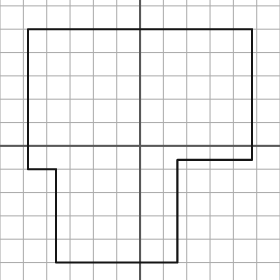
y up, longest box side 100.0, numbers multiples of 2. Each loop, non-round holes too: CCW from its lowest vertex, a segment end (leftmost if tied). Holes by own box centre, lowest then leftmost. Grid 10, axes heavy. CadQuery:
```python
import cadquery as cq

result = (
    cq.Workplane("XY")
    .moveTo(-36.0, -50.0)
    .lineTo(16.0, -50.0)
    .lineTo(16.0, -6.0)
    .lineTo(48.0, -6.0)
    .lineTo(48.0, 50.0)
    .lineTo(-48.0, 50.0)
    .lineTo(-48.0, -10.0)
    .lineTo(-36.0, -10.0)
    .close()
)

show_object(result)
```